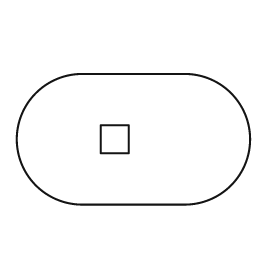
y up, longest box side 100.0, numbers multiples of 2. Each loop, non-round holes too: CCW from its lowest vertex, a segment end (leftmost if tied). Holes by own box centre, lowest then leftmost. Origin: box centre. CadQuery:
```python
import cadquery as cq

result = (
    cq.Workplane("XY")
    .moveTo(-22.0, -28.0)
    .lineTo(22.0, -28.0)
    .threePointArc((50.0, 0.0), (22.0, 28.0))
    .lineTo(-22.0, 28.0)
    .threePointArc((-50.0, 0.0), (-22.0, -28.0))
    .close()
    .moveTo(-14.0, -6.0)
    .lineTo(-2.0, -6.0)
    .lineTo(-2.0, 6.0)
    .lineTo(-14.0, 6.0)
    .close()
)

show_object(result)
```